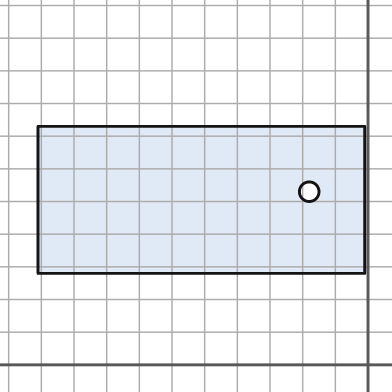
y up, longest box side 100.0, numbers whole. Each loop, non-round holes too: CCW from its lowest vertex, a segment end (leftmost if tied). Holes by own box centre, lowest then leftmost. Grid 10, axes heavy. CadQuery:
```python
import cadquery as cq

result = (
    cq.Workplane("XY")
    .moveTo(-101.0, 28.0)
    .lineTo(-1.0, 28.0)
    .lineTo(-1.0, 73.0)
    .lineTo(-101.0, 73.0)
    .close()
    .moveTo(-18.0, 53.0)
    .circle(3.0)
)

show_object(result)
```